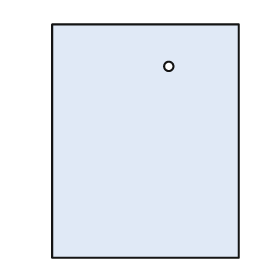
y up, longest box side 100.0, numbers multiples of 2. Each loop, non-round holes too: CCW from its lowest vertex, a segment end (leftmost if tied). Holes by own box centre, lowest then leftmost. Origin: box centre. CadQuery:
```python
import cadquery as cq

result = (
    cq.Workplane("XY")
    .moveTo(-40.0, -50.0)
    .lineTo(40.0, -50.0)
    .lineTo(40.0, 50.0)
    .lineTo(-40.0, 50.0)
    .close()
    .moveTo(10.0, 32.0)
    .circle(2.0)
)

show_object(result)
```